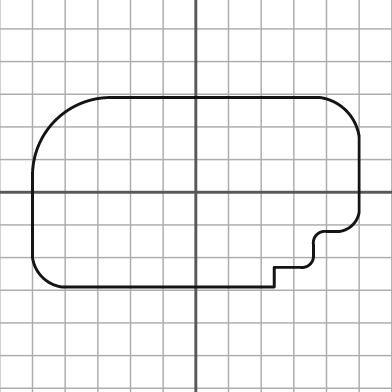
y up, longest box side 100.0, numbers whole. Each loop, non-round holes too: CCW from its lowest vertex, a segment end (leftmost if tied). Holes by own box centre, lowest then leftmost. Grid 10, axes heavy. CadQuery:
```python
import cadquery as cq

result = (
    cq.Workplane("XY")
    .moveTo(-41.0, -29.0)
    .lineTo(24.0, -29.0)
    .lineTo(24.0, -23.0)
    .lineTo(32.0, -23.0)
    .threePointArc((35.0, -22.0), (36.0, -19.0))
    .lineTo(36.0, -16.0)
    .threePointArc((37.0, -13.0), (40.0, -12.0))
    .lineTo(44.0, -12.0)
    .threePointArc((48.0, -10.0), (50.0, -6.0))
    .lineTo(50.0, 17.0)
    .threePointArc((46.0, 25.0), (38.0, 29.0))
    .lineTo(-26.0, 29.0)
    .threePointArc((-43.0, 22.0), (-50.0, 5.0))
    .lineTo(-50.0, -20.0)
    .threePointArc((-47.0, -26.0), (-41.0, -29.0))
    .close()
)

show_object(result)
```